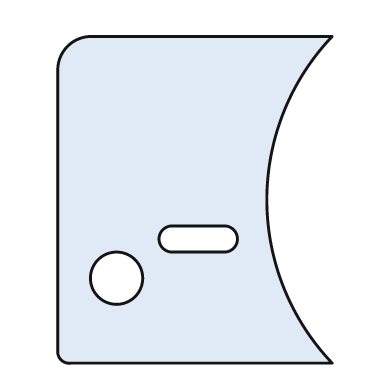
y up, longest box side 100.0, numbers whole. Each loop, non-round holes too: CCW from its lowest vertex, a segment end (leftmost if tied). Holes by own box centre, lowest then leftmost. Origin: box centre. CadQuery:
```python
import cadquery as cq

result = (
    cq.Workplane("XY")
    .moveTo(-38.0, -50.0)
    .lineTo(42.0, -50.0)
    .threePointArc((22.0, 0.0), (42.0, 50.0))
    .lineTo(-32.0, 50.0)
    .threePointArc((-39.0, 47.0), (-42.0, 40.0))
    .lineTo(-42.0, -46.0)
    .threePointArc((-41.0, -49.0), (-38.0, -50.0))
    .close()
    .moveTo(-24.0, -24.0)
    .circle(8.0)
    .moveTo(-7.0, -16.0)
    .lineTo(9.0, -16.0)
    .threePointArc((13.0, -12.0), (9.0, -8.0))
    .lineTo(-7.0, -8.0)
    .threePointArc((-11.0, -12.0), (-7.0, -16.0))
    .close()
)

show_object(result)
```